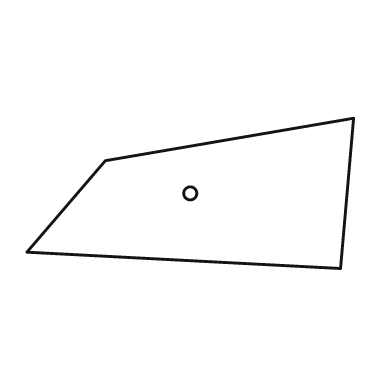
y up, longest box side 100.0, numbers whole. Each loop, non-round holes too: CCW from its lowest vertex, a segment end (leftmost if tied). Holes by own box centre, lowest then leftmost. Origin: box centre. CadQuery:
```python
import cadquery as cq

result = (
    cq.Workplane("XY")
    .moveTo(46.0, -23.0)
    .lineTo(50.0, 23.0)
    .lineTo(-26.0, 10.0)
    .lineTo(-50.0, -18.0)
    .close()
    .moveTo(0.0, 0.0)
    .circle(2.0)
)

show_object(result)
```